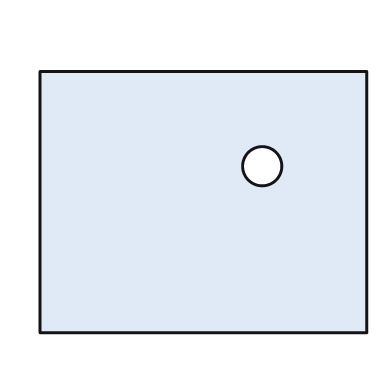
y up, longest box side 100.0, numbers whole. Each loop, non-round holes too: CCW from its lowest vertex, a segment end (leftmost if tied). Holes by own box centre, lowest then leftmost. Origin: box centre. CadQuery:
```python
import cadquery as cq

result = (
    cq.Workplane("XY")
    .moveTo(-50.0, -40.0)
    .lineTo(50.0, -40.0)
    .lineTo(50.0, 40.0)
    .lineTo(-50.0, 40.0)
    .close()
    .moveTo(18.0, 11.0)
    .circle(6.0)
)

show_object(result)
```